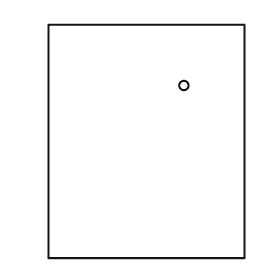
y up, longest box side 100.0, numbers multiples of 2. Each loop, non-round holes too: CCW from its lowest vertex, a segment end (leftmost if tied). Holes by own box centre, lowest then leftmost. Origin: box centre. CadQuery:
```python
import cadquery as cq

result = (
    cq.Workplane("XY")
    .moveTo(-42.0, -50.0)
    .lineTo(42.0, -50.0)
    .lineTo(42.0, 50.0)
    .lineTo(-42.0, 50.0)
    .close()
    .moveTo(16.0, 24.0)
    .circle(2.0)
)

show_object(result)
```